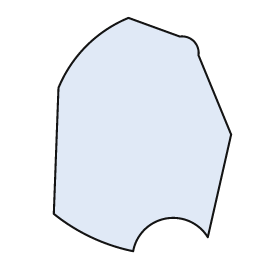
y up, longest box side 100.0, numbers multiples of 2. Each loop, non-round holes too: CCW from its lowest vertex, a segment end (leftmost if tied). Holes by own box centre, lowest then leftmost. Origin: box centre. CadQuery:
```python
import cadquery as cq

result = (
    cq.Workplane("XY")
    .moveTo(-4.0, -50.0)
    .threePointArc((10.0, -36.0), (28.0, -44.0))
    .lineTo(38.0, 0.0)
    .lineTo(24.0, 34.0)
    .threePointArc((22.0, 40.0), (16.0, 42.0))
    .lineTo(-6.0, 50.0)
    .threePointArc((-24.0, 38.0), (-36.0, 20.0))
    .lineTo(-38.0, -34.0)
    .threePointArc((-22.0, -44.0), (-4.0, -50.0))
    .close()
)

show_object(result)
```